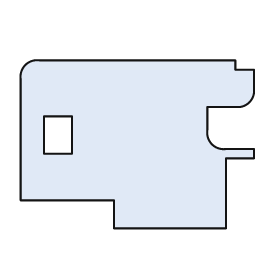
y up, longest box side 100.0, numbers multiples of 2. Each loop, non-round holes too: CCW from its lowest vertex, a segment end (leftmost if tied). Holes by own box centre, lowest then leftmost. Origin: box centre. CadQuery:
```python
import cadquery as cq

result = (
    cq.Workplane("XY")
    .moveTo(-10.0, -36.0)
    .lineTo(38.0, -36.0)
    .lineTo(38.0, -6.0)
    .lineTo(50.0, -6.0)
    .lineTo(50.0, -2.0)
    .lineTo(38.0, -2.0)
    .threePointArc((32.0, 0.0), (30.0, 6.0))
    .lineTo(30.0, 16.0)
    .lineTo(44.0, 16.0)
    .threePointArc((48.0, 18.0), (50.0, 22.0))
    .lineTo(50.0, 32.0)
    .lineTo(42.0, 32.0)
    .lineTo(42.0, 36.0)
    .lineTo(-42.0, 36.0)
    .threePointArc((-48.0, 34.0), (-50.0, 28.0))
    .lineTo(-50.0, -24.0)
    .lineTo(-10.0, -24.0)
    .close()
    .moveTo(-40.0, -4.0)
    .lineTo(-28.0, -4.0)
    .lineTo(-28.0, 12.0)
    .lineTo(-40.0, 12.0)
    .close()
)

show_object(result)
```